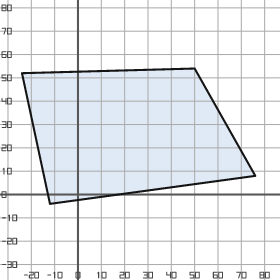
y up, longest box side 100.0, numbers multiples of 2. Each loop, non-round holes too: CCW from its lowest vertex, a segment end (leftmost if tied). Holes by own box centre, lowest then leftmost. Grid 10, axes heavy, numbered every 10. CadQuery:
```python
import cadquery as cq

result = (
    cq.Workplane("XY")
    .moveTo(-12.0, -4.0)
    .lineTo(76.0, 8.0)
    .lineTo(50.0, 54.0)
    .lineTo(-24.0, 52.0)
    .close()
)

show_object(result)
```